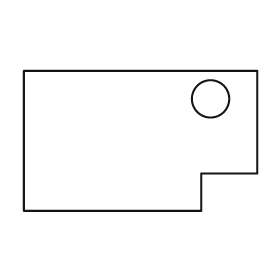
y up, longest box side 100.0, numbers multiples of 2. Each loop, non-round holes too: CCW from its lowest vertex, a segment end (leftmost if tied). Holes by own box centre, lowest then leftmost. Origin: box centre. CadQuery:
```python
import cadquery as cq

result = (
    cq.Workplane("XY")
    .moveTo(-50.0, -30.0)
    .lineTo(26.0, -30.0)
    .lineTo(26.0, -14.0)
    .lineTo(50.0, -14.0)
    .lineTo(50.0, 30.0)
    .lineTo(-50.0, 30.0)
    .close()
    .moveTo(30.0, 18.0)
    .circle(8.0)
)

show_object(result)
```